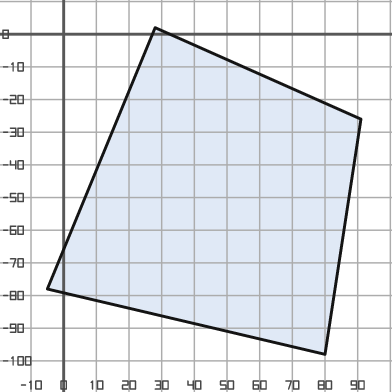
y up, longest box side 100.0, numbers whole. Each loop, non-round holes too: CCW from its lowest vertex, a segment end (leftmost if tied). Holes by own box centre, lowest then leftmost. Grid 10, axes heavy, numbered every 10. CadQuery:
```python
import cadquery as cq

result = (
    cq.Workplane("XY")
    .moveTo(80.0, -98.0)
    .lineTo(91.0, -26.0)
    .lineTo(28.0, 2.0)
    .lineTo(-5.0, -78.0)
    .close()
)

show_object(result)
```